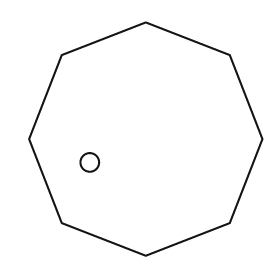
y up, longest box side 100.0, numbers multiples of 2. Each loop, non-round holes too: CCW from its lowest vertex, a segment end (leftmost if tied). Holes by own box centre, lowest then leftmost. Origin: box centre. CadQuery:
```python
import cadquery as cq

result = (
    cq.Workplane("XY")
    .moveTo(0.0, -50.0)
    .lineTo(36.0, -36.0)
    .lineTo(50.0, 0.0)
    .lineTo(36.0, 36.0)
    .lineTo(0.0, 50.0)
    .lineTo(-36.0, 36.0)
    .lineTo(-50.0, 0.0)
    .lineTo(-36.0, -36.0)
    .close()
    .moveTo(-24.0, -10.0)
    .circle(4.0)
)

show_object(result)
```